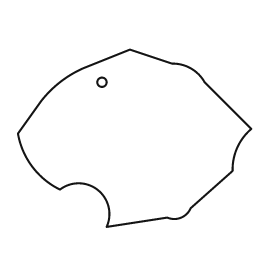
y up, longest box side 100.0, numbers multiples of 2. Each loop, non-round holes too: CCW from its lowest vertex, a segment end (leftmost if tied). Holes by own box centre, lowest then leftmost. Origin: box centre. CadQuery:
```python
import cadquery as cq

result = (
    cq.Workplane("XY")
    .moveTo(-12.0, -38.0)
    .lineTo(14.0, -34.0)
    .threePointArc((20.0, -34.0), (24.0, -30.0))
    .lineTo(42.0, -14.0)
    .threePointArc((44.0, -4.0), (50.0, 4.0))
    .lineTo(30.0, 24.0)
    .threePointArc((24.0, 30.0), (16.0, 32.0))
    .lineTo(-2.0, 38.0)
    .lineTo(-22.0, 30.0)
    .threePointArc((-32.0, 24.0), (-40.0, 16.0))
    .lineTo(-50.0, 2.0)
    .threePointArc((-44.0, -12.0), (-32.0, -22.0))
    .threePointArc((-16.0, -22.0), (-12.0, -38.0))
    .close()
    .moveTo(-14.0, 24.0)
    .circle(2.0)
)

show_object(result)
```